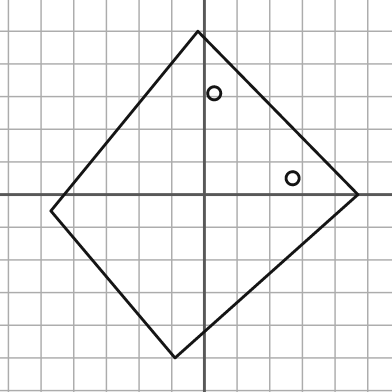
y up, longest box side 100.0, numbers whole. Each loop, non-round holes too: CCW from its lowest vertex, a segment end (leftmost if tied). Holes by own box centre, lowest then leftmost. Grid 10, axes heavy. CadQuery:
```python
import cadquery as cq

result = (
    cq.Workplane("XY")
    .moveTo(-9.0, -50.0)
    .lineTo(47.0, 0.0)
    .lineTo(-2.0, 50.0)
    .lineTo(-47.0, -5.0)
    .close()
    .moveTo(27.0, 5.0)
    .circle(2.0)
    .moveTo(3.0, 31.0)
    .circle(2.0)
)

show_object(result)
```